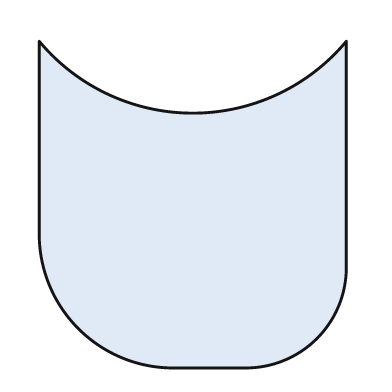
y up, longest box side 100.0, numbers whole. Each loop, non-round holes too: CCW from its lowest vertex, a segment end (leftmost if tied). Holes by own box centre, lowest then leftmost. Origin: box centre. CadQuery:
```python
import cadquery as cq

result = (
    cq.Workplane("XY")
    .moveTo(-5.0, -50.0)
    .lineTo(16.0, -50.0)
    .threePointArc((38.0, -41.0), (47.0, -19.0))
    .lineTo(47.0, 50.0)
    .threePointArc((0.0, 28.0), (-47.0, 50.0))
    .lineTo(-47.0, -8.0)
    .threePointArc((-35.0, -38.0), (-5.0, -50.0))
    .close()
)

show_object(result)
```